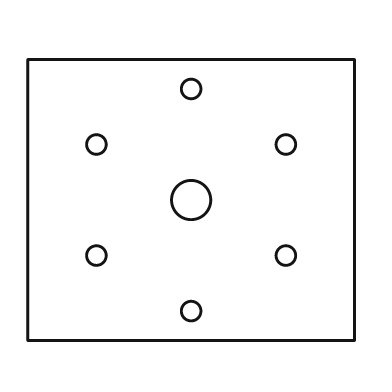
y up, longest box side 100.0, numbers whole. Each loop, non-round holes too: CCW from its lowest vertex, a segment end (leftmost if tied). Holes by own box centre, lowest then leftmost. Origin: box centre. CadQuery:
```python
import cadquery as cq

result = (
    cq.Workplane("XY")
    .moveTo(-50.0, -43.0)
    .lineTo(50.0, -43.0)
    .lineTo(50.0, 43.0)
    .lineTo(-50.0, 43.0)
    .close()
    .moveTo(0.0, -34.0)
    .circle(3.0)
    .moveTo(-29.0, -17.0)
    .circle(3.0)
    .moveTo(29.0, -17.0)
    .circle(3.0)
    .moveTo(0.0, 0.0)
    .circle(6.0)
    .moveTo(-29.0, 17.0)
    .circle(3.0)
    .moveTo(29.0, 17.0)
    .circle(3.0)
    .moveTo(0.0, 34.0)
    .circle(3.0)
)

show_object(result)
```